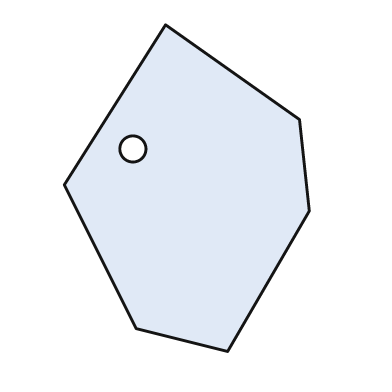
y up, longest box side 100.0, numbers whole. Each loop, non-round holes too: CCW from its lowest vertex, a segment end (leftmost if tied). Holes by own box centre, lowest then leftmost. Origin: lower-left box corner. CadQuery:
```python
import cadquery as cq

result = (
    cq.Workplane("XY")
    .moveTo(50.0, 0.0)
    .lineTo(75.0, 43.0)
    .lineTo(72.0, 71.0)
    .lineTo(31.0, 100.0)
    .lineTo(0.0, 51.0)
    .lineTo(22.0, 7.0)
    .close()
    .moveTo(21.0, 62.0)
    .circle(4.0)
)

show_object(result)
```